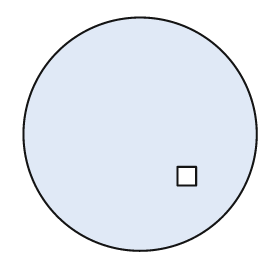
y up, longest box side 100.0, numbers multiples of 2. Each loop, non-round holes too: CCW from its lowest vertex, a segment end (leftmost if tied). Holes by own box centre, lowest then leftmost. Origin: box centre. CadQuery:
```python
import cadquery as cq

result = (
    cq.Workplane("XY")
    .moveTo(0.0, 0.0)
    .circle(50.0)
    .moveTo(16.0, -22.0)
    .lineTo(24.0, -22.0)
    .lineTo(24.0, -14.0)
    .lineTo(16.0, -14.0)
    .close()
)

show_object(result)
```